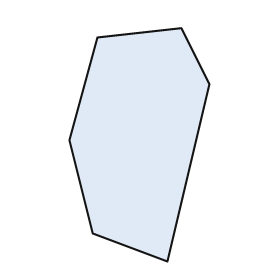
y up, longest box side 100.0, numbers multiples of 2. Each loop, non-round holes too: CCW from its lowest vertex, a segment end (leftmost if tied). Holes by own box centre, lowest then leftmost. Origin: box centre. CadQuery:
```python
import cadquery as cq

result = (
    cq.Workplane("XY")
    .moveTo(12.0, -50.0)
    .lineTo(30.0, 26.0)
    .lineTo(18.0, 50.0)
    .lineTo(-18.0, 46.0)
    .lineTo(-30.0, 2.0)
    .lineTo(-20.0, -38.0)
    .close()
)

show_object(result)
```